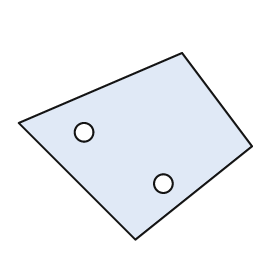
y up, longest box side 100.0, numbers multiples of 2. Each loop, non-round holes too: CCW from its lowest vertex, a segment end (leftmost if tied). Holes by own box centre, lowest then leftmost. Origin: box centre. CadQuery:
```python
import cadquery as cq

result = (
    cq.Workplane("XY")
    .moveTo(0.0, -40.0)
    .lineTo(50.0, 0.0)
    .lineTo(20.0, 40.0)
    .lineTo(-50.0, 10.0)
    .close()
    .moveTo(12.0, -16.0)
    .circle(4.0)
    .moveTo(-22.0, 6.0)
    .circle(4.0)
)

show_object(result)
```